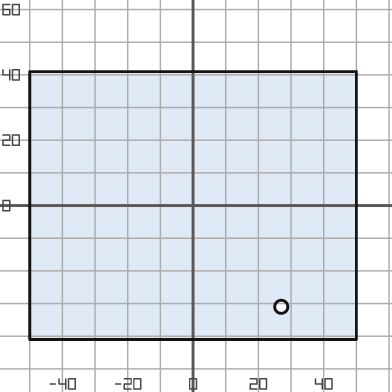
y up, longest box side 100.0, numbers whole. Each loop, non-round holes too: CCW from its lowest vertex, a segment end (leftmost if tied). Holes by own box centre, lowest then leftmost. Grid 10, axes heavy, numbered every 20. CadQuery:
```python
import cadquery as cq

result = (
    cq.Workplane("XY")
    .moveTo(-50.0, -41.0)
    .lineTo(50.0, -41.0)
    .lineTo(50.0, 41.0)
    .lineTo(-50.0, 41.0)
    .close()
    .moveTo(27.0, -31.0)
    .circle(2.0)
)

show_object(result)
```